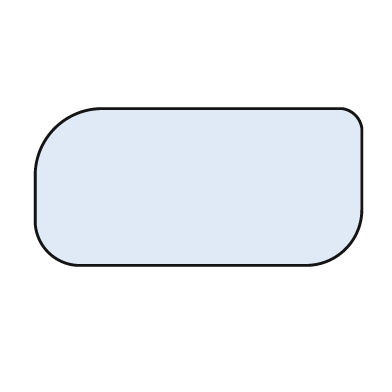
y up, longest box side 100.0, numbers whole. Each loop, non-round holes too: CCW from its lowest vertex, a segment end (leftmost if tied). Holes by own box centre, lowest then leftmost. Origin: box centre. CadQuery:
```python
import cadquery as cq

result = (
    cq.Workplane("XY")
    .moveTo(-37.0, -24.0)
    .lineTo(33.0, -24.0)
    .threePointArc((45.0, -19.0), (50.0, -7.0))
    .lineTo(50.0, 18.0)
    .threePointArc((48.0, 22.0), (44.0, 24.0))
    .lineTo(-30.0, 24.0)
    .threePointArc((-44.0, 18.0), (-50.0, 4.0))
    .lineTo(-50.0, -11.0)
    .threePointArc((-46.0, -20.0), (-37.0, -24.0))
    .close()
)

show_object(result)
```